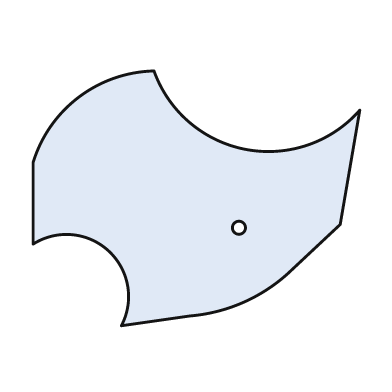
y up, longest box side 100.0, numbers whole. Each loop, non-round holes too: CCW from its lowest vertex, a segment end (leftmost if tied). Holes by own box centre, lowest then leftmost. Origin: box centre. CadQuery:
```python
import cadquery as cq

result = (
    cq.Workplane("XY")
    .moveTo(-23.0, -39.0)
    .lineTo(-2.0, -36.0)
    .threePointArc((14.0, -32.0), (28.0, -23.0))
    .lineTo(44.0, -8.0)
    .lineTo(50.0, 27.0)
    .threePointArc((15.0, 15.0), (-13.0, 39.0))
    .threePointArc((-36.0, 31.0), (-50.0, 11.0))
    .lineTo(-50.0, -14.0)
    .threePointArc((-27.0, -16.0), (-23.0, -39.0))
    .close()
    .moveTo(13.0, -9.0)
    .circle(2.0)
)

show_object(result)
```